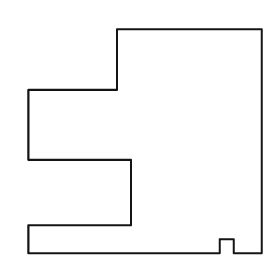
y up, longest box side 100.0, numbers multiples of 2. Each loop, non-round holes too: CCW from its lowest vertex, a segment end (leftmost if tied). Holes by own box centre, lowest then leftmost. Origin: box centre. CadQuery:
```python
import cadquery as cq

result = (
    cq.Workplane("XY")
    .moveTo(-50.0, -48.0)
    .lineTo(32.0, -48.0)
    .lineTo(32.0, -42.0)
    .lineTo(38.0, -42.0)
    .lineTo(38.0, -48.0)
    .lineTo(50.0, -48.0)
    .lineTo(50.0, 48.0)
    .lineTo(-12.0, 48.0)
    .lineTo(-12.0, 22.0)
    .lineTo(-50.0, 22.0)
    .lineTo(-50.0, -8.0)
    .lineTo(-6.0, -8.0)
    .lineTo(-6.0, -36.0)
    .lineTo(-50.0, -36.0)
    .close()
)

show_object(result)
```